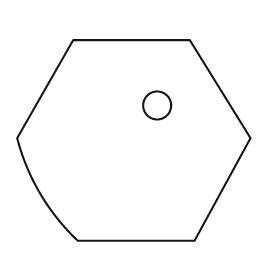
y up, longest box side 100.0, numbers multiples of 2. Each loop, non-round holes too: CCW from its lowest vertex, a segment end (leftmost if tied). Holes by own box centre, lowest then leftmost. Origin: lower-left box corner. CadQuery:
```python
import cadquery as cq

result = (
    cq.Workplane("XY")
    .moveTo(26.0, 0.0)
    .lineTo(76.0, 0.0)
    .lineTo(100.0, 44.0)
    .lineTo(74.0, 86.0)
    .lineTo(24.0, 86.0)
    .lineTo(0.0, 44.0)
    .threePointArc((10.0, 20.0), (26.0, 0.0))
    .close()
    .moveTo(60.0, 58.0)
    .circle(6.0)
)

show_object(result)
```